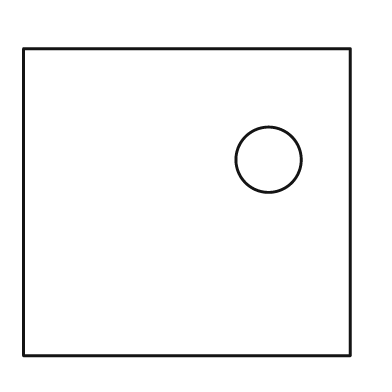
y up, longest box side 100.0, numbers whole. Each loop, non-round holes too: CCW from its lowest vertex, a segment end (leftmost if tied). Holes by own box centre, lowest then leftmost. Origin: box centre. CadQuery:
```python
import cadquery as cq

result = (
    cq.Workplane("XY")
    .moveTo(-50.0, -47.0)
    .lineTo(50.0, -47.0)
    .lineTo(50.0, 47.0)
    .lineTo(-50.0, 47.0)
    .close()
    .moveTo(25.0, 13.0)
    .circle(10.0)
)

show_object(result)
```